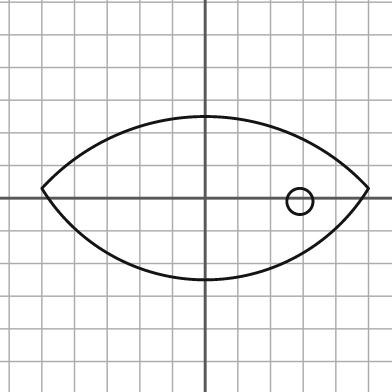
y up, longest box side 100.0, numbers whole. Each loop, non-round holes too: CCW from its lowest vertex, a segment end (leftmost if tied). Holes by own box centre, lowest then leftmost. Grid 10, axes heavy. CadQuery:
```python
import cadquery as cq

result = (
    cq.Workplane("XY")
    .moveTo(-50.0, 3.0)
    .threePointArc((0.0, -25.0), (50.0, 3.0))
    .threePointArc((0.0, 25.0), (-50.0, 3.0))
    .close()
    .moveTo(29.0, -1.0)
    .circle(4.0)
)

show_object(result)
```